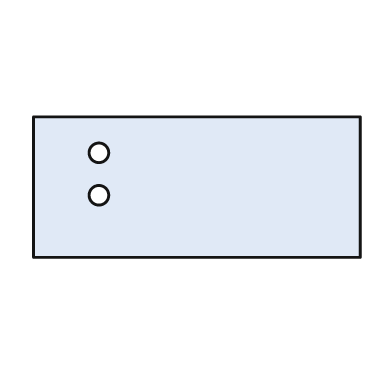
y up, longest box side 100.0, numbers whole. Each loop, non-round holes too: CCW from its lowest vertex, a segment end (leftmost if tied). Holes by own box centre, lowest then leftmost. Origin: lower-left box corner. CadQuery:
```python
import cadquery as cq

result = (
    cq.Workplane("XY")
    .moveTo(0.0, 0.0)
    .lineTo(100.0, 0.0)
    .lineTo(100.0, 43.0)
    .lineTo(0.0, 43.0)
    .close()
    .moveTo(20.0, 19.0)
    .circle(3.0)
    .moveTo(20.0, 32.0)
    .circle(3.0)
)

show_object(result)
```